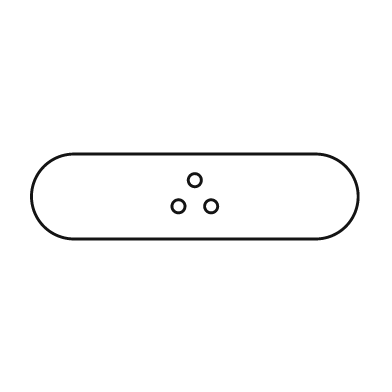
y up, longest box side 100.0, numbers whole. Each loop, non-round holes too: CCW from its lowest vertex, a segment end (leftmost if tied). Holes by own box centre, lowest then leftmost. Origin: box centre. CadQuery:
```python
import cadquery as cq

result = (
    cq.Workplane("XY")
    .moveTo(-37.0, -13.0)
    .lineTo(37.0, -13.0)
    .threePointArc((50.0, 0.0), (37.0, 13.0))
    .lineTo(-37.0, 13.0)
    .threePointArc((-50.0, 0.0), (-37.0, -13.0))
    .close()
    .moveTo(-5.0, -3.0)
    .circle(2.0)
    .moveTo(5.0, -3.0)
    .circle(2.0)
    .moveTo(0.0, 5.0)
    .circle(2.0)
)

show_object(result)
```